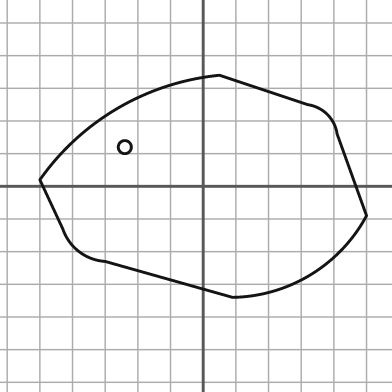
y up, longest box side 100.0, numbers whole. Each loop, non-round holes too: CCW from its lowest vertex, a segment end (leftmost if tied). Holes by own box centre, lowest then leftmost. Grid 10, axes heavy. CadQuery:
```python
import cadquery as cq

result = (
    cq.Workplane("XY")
    .moveTo(9.0, -34.0)
    .threePointArc((33.0, -27.0), (50.0, -9.0))
    .lineTo(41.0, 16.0)
    .threePointArc((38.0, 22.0), (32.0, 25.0))
    .lineTo(5.0, 34.0)
    .threePointArc((-26.0, 24.0), (-50.0, 2.0))
    .lineTo(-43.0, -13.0)
    .threePointArc((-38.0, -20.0), (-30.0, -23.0))
    .close()
    .moveTo(-24.0, 12.0)
    .circle(2.0)
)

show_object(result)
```